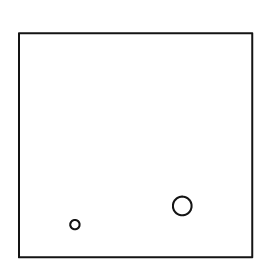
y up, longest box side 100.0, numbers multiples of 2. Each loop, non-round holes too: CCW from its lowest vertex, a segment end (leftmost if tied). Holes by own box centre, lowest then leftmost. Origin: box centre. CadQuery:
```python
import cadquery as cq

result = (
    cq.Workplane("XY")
    .moveTo(-50.0, -48.0)
    .lineTo(50.0, -48.0)
    .lineTo(50.0, 48.0)
    .lineTo(-50.0, 48.0)
    .close()
    .moveTo(-26.0, -34.0)
    .circle(2.0)
    .moveTo(20.0, -26.0)
    .circle(4.0)
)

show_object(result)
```